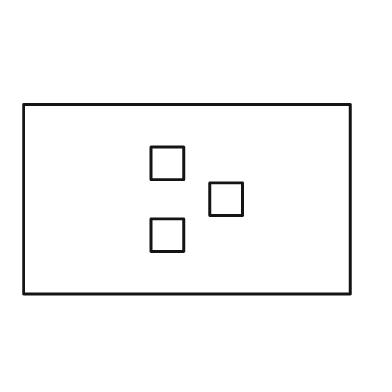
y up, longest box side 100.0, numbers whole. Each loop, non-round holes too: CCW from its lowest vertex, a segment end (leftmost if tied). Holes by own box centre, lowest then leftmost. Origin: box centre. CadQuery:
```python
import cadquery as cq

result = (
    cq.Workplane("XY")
    .moveTo(-50.0, -29.0)
    .lineTo(50.0, -29.0)
    .lineTo(50.0, 29.0)
    .lineTo(-50.0, 29.0)
    .close()
    .moveTo(-11.0, -16.0)
    .lineTo(-1.0, -16.0)
    .lineTo(-1.0, -6.0)
    .lineTo(-11.0, -6.0)
    .close()
    .moveTo(7.0, -5.0)
    .lineTo(17.0, -5.0)
    .lineTo(17.0, 5.0)
    .lineTo(7.0, 5.0)
    .close()
    .moveTo(-11.0, 6.0)
    .lineTo(-1.0, 6.0)
    .lineTo(-1.0, 16.0)
    .lineTo(-11.0, 16.0)
    .close()
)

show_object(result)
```